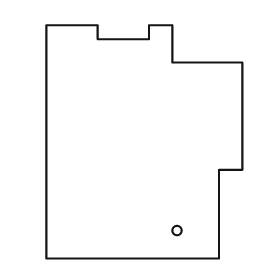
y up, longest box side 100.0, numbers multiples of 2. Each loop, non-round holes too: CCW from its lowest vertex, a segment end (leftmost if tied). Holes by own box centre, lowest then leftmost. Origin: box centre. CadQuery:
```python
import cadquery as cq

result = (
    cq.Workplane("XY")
    .moveTo(-42.0, -50.0)
    .lineTo(32.0, -50.0)
    .lineTo(32.0, -12.0)
    .lineTo(42.0, -12.0)
    .lineTo(42.0, 34.0)
    .lineTo(12.0, 34.0)
    .lineTo(12.0, 50.0)
    .lineTo(2.0, 50.0)
    .lineTo(2.0, 44.0)
    .lineTo(-20.0, 44.0)
    .lineTo(-20.0, 50.0)
    .lineTo(-42.0, 50.0)
    .close()
    .moveTo(14.0, -38.0)
    .circle(2.0)
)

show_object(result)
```